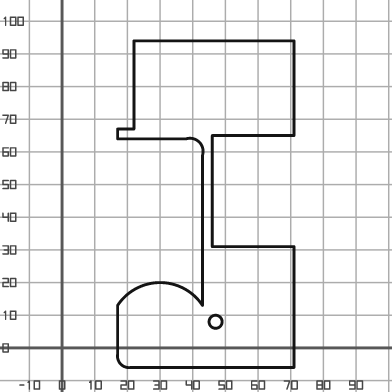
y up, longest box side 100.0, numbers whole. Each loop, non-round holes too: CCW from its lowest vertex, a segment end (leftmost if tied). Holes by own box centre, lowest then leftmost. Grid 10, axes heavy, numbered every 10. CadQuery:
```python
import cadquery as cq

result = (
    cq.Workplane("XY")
    .moveTo(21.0, -6.0)
    .lineTo(71.0, -6.0)
    .lineTo(71.0, 31.0)
    .lineTo(46.0, 31.0)
    .lineTo(46.0, 65.0)
    .lineTo(71.0, 65.0)
    .lineTo(71.0, 94.0)
    .lineTo(22.0, 94.0)
    .lineTo(22.0, 67.0)
    .lineTo(17.0, 67.0)
    .lineTo(17.0, 64.0)
    .lineTo(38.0, 64.0)
    .threePointArc((42.0, 63.0), (43.0, 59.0))
    .lineTo(43.0, 13.0)
    .threePointArc((30.0, 20.0), (17.0, 13.0))
    .lineTo(17.0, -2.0)
    .threePointArc((18.0, -5.0), (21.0, -6.0))
    .close()
    .moveTo(47.0, 8.0)
    .circle(2.0)
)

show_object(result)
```